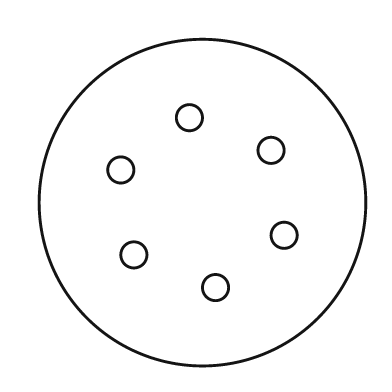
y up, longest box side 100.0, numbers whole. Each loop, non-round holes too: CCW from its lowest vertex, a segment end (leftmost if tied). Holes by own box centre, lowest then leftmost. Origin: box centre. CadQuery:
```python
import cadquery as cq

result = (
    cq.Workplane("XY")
    .moveTo(0.0, 0.0)
    .circle(50.0)
    .moveTo(4.0, -26.0)
    .circle(4.0)
    .moveTo(-21.0, -16.0)
    .circle(4.0)
    .moveTo(25.0, -10.0)
    .circle(4.0)
    .moveTo(-25.0, 10.0)
    .circle(4.0)
    .moveTo(21.0, 16.0)
    .circle(4.0)
    .moveTo(-4.0, 26.0)
    .circle(4.0)
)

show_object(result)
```